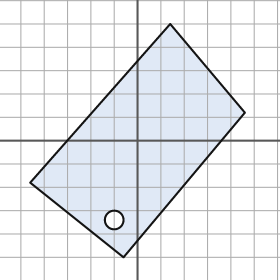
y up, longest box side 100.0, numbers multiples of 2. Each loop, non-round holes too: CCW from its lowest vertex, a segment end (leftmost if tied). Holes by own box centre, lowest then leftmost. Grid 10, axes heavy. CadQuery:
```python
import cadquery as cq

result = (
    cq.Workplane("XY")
    .moveTo(-6.0, -50.0)
    .lineTo(46.0, 12.0)
    .lineTo(14.0, 50.0)
    .lineTo(-46.0, -18.0)
    .close()
    .moveTo(-10.0, -34.0)
    .circle(4.0)
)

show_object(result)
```